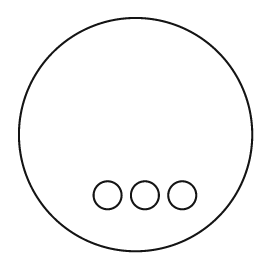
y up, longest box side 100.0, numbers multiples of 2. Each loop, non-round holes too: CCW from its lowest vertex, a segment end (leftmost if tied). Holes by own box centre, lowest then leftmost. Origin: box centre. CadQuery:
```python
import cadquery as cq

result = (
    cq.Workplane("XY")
    .moveTo(0.0, 0.0)
    .circle(50.0)
    .moveTo(-12.0, -26.0)
    .circle(6.0)
    .moveTo(4.0, -26.0)
    .circle(6.0)
    .moveTo(20.0, -26.0)
    .circle(6.0)
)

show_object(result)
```